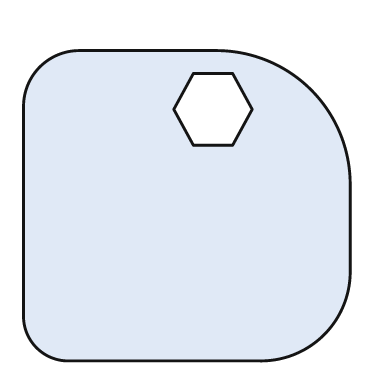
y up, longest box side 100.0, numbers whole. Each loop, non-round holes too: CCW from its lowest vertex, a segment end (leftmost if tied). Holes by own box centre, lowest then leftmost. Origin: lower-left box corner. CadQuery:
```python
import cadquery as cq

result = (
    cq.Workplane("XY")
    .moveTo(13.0, 0.0)
    .lineTo(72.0, 0.0)
    .threePointArc((92.0, 8.0), (100.0, 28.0))
    .lineTo(100.0, 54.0)
    .threePointArc((88.0, 83.0), (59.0, 95.0))
    .lineTo(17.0, 95.0)
    .threePointArc((5.0, 90.0), (0.0, 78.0))
    .lineTo(0.0, 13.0)
    .threePointArc((4.0, 4.0), (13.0, 0.0))
    .close()
    .moveTo(52.0, 66.0)
    .lineTo(64.0, 66.0)
    .lineTo(70.0, 77.0)
    .lineTo(64.0, 88.0)
    .lineTo(52.0, 88.0)
    .lineTo(46.0, 77.0)
    .close()
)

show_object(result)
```